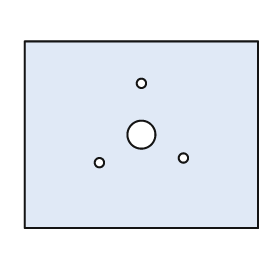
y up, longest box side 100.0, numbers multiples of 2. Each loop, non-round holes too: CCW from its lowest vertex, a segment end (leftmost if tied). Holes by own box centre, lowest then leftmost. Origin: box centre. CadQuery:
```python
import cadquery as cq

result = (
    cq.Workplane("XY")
    .moveTo(-50.0, -40.0)
    .lineTo(50.0, -40.0)
    .lineTo(50.0, 40.0)
    .lineTo(-50.0, 40.0)
    .close()
    .moveTo(-18.0, -12.0)
    .circle(2.0)
    .moveTo(18.0, -10.0)
    .circle(2.0)
    .moveTo(0.0, 0.0)
    .circle(6.0)
    .moveTo(0.0, 22.0)
    .circle(2.0)
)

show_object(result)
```